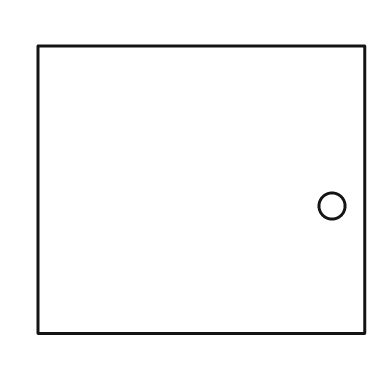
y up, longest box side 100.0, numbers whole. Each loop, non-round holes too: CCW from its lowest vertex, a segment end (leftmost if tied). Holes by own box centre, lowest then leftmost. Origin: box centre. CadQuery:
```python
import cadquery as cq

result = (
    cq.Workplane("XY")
    .moveTo(-50.0, -44.0)
    .lineTo(50.0, -44.0)
    .lineTo(50.0, 44.0)
    .lineTo(-50.0, 44.0)
    .close()
    .moveTo(40.0, -5.0)
    .circle(4.0)
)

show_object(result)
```